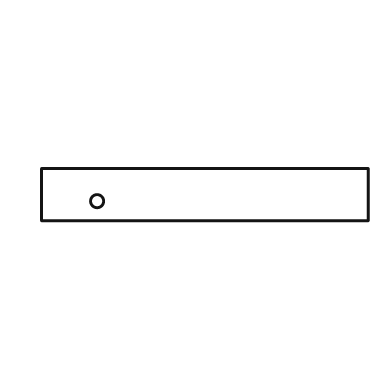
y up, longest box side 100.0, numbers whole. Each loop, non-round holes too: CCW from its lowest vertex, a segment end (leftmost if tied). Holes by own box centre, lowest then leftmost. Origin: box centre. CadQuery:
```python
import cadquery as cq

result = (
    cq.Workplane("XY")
    .moveTo(-50.0, -8.0)
    .lineTo(50.0, -8.0)
    .lineTo(50.0, 8.0)
    .lineTo(-50.0, 8.0)
    .close()
    .moveTo(-33.0, -2.0)
    .circle(2.0)
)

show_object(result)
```